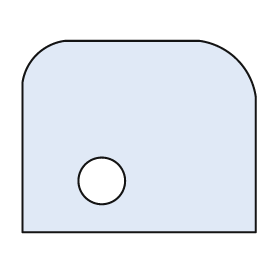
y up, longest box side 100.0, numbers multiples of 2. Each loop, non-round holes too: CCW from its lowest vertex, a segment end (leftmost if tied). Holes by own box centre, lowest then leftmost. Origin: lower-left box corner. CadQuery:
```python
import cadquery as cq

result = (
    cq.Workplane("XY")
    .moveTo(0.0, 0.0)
    .lineTo(100.0, 0.0)
    .lineTo(100.0, 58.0)
    .threePointArc((92.0, 74.0), (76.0, 82.0))
    .lineTo(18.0, 82.0)
    .threePointArc((6.0, 76.0), (0.0, 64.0))
    .close()
    .moveTo(34.0, 22.0)
    .circle(10.0)
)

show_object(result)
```